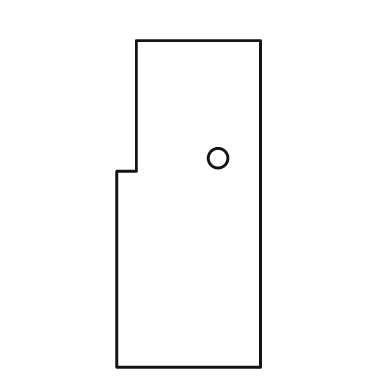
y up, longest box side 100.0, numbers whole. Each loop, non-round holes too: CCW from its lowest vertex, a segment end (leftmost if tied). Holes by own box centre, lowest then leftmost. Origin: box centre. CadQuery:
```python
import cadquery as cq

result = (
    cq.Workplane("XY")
    .moveTo(-22.0, -50.0)
    .lineTo(22.0, -50.0)
    .lineTo(22.0, 50.0)
    .lineTo(-16.0, 50.0)
    .lineTo(-16.0, 10.0)
    .lineTo(-22.0, 10.0)
    .close()
    .moveTo(9.0, 14.0)
    .circle(3.0)
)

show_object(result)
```